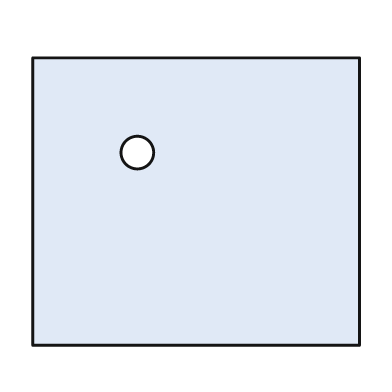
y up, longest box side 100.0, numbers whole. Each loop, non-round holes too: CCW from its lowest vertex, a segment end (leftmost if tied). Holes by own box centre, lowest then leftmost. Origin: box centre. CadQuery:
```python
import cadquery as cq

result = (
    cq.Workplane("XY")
    .moveTo(-50.0, -44.0)
    .lineTo(50.0, -44.0)
    .lineTo(50.0, 44.0)
    .lineTo(-50.0, 44.0)
    .close()
    .moveTo(-18.0, 15.0)
    .circle(5.0)
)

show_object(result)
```